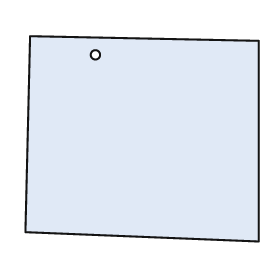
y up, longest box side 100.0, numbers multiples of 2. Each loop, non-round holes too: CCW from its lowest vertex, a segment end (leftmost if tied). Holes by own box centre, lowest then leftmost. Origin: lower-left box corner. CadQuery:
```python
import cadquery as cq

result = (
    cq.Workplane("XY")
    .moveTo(100.0, 0.0)
    .lineTo(100.0, 86.0)
    .lineTo(2.0, 88.0)
    .lineTo(0.0, 4.0)
    .close()
    .moveTo(30.0, 80.0)
    .circle(2.0)
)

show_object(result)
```